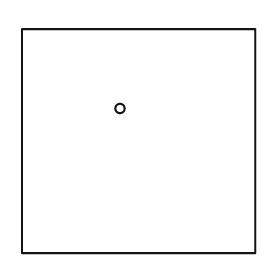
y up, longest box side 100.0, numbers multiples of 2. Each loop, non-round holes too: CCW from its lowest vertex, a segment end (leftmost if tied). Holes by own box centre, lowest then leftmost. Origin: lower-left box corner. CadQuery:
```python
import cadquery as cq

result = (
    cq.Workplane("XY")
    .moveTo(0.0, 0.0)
    .lineTo(100.0, 0.0)
    .lineTo(100.0, 96.0)
    .lineTo(0.0, 96.0)
    .close()
    .moveTo(42.0, 62.0)
    .circle(2.0)
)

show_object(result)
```